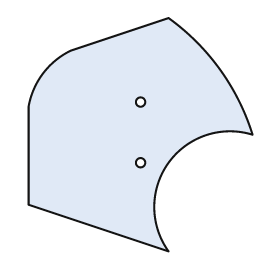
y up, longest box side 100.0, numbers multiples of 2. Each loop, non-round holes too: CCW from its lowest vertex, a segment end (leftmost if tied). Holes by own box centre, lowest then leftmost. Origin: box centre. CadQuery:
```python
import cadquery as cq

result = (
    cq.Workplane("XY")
    .moveTo(12.0, -50.0)
    .threePointArc((12.0, -12.0), (48.0, 0.0))
    .threePointArc((34.0, 28.0), (12.0, 50.0))
    .lineTo(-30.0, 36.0)
    .threePointArc((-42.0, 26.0), (-48.0, 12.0))
    .lineTo(-48.0, -30.0)
    .close()
    .moveTo(0.0, -12.0)
    .circle(2.0)
    .moveTo(0.0, 14.0)
    .circle(2.0)
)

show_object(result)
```